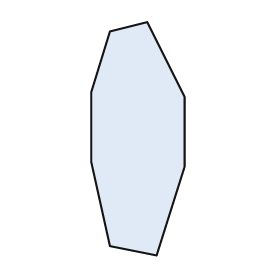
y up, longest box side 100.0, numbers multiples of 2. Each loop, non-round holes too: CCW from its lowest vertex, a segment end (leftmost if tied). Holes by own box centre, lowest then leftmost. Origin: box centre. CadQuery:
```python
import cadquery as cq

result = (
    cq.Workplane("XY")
    .moveTo(8.0, -50.0)
    .lineTo(20.0, -12.0)
    .lineTo(20.0, 18.0)
    .lineTo(4.0, 50.0)
    .lineTo(-12.0, 46.0)
    .lineTo(-20.0, 20.0)
    .lineTo(-20.0, -10.0)
    .lineTo(-12.0, -46.0)
    .close()
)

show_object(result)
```